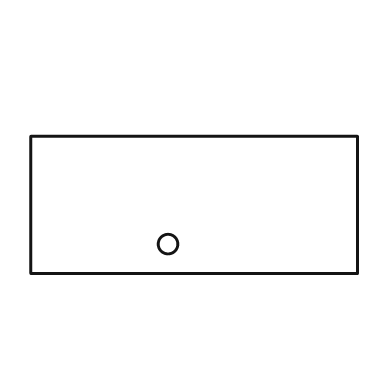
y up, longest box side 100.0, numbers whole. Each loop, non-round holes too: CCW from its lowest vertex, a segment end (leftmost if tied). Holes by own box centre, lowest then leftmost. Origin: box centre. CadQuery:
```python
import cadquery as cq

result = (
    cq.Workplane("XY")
    .moveTo(-50.0, -21.0)
    .lineTo(50.0, -21.0)
    .lineTo(50.0, 21.0)
    .lineTo(-50.0, 21.0)
    .close()
    .moveTo(-8.0, -12.0)
    .circle(3.0)
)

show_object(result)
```